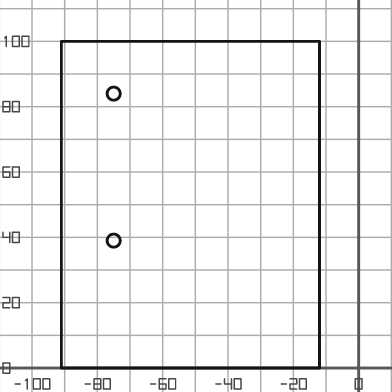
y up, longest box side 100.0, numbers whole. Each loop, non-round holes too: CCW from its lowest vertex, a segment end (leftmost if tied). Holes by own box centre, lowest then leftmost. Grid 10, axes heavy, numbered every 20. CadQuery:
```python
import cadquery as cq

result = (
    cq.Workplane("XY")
    .moveTo(-91.0, 0.0)
    .lineTo(-12.0, 0.0)
    .lineTo(-12.0, 100.0)
    .lineTo(-91.0, 100.0)
    .close()
    .moveTo(-75.0, 39.0)
    .circle(2.0)
    .moveTo(-75.0, 84.0)
    .circle(2.0)
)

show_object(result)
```